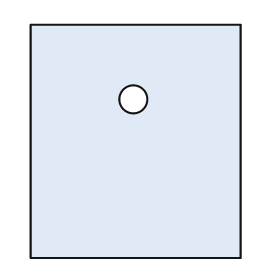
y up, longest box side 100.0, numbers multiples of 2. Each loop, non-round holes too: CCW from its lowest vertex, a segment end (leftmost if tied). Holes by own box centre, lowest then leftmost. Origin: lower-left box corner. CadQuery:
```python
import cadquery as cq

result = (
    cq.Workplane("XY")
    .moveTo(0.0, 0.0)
    .lineTo(90.0, 0.0)
    .lineTo(90.0, 100.0)
    .lineTo(0.0, 100.0)
    .close()
    .moveTo(44.0, 68.0)
    .circle(6.0)
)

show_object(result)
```